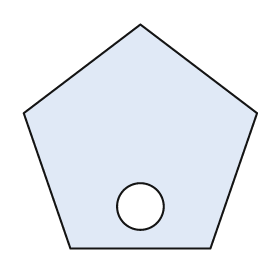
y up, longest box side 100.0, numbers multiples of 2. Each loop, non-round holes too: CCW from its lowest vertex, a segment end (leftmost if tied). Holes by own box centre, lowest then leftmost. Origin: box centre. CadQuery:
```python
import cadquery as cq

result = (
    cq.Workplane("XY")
    .moveTo(-30.0, -48.0)
    .lineTo(30.0, -48.0)
    .lineTo(50.0, 10.0)
    .lineTo(0.0, 48.0)
    .lineTo(-50.0, 10.0)
    .close()
    .moveTo(0.0, -30.0)
    .circle(10.0)
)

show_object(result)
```